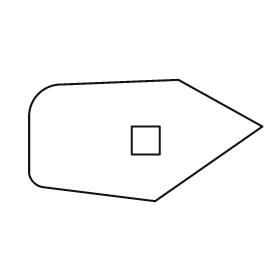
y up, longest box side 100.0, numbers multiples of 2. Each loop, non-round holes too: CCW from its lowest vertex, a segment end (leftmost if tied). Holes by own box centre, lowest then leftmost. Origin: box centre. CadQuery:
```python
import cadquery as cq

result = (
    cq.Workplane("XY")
    .moveTo(4.0, -26.0)
    .lineTo(50.0, 6.0)
    .lineTo(14.0, 26.0)
    .lineTo(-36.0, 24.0)
    .threePointArc((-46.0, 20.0), (-50.0, 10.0))
    .lineTo(-50.0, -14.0)
    .threePointArc((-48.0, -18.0), (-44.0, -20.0))
    .close()
    .moveTo(-6.0, -6.0)
    .lineTo(6.0, -6.0)
    .lineTo(6.0, 6.0)
    .lineTo(-6.0, 6.0)
    .close()
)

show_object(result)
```